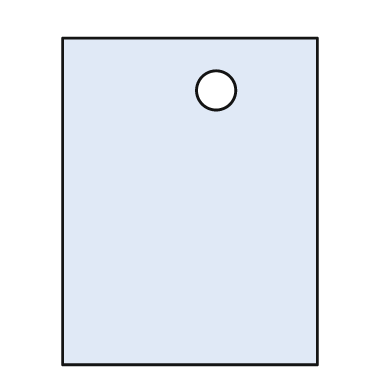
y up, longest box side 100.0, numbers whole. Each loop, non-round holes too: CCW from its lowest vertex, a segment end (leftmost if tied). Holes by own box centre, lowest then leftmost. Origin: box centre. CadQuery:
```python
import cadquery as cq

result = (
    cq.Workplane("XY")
    .moveTo(-39.0, -50.0)
    .lineTo(39.0, -50.0)
    .lineTo(39.0, 50.0)
    .lineTo(-39.0, 50.0)
    .close()
    .moveTo(8.0, 34.0)
    .circle(6.0)
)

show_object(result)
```